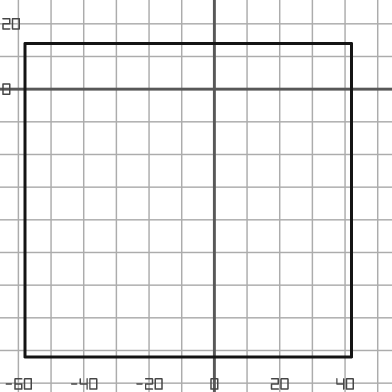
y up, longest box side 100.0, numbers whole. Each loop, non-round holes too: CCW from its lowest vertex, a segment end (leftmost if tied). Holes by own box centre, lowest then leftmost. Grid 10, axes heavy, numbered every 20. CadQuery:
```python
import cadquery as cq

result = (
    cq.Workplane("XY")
    .moveTo(-58.0, -82.0)
    .lineTo(42.0, -82.0)
    .lineTo(42.0, 14.0)
    .lineTo(-58.0, 14.0)
    .close()
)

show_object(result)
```